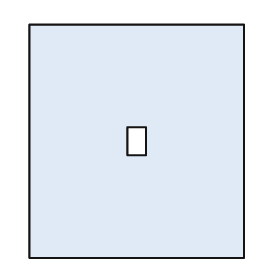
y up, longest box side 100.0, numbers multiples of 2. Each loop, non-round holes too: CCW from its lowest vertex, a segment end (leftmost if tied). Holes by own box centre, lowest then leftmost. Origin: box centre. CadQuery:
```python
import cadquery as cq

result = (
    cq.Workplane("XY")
    .moveTo(-46.0, -50.0)
    .lineTo(46.0, -50.0)
    .lineTo(46.0, 50.0)
    .lineTo(-46.0, 50.0)
    .close()
    .moveTo(-4.0, -6.0)
    .lineTo(4.0, -6.0)
    .lineTo(4.0, 6.0)
    .lineTo(-4.0, 6.0)
    .close()
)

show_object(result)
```